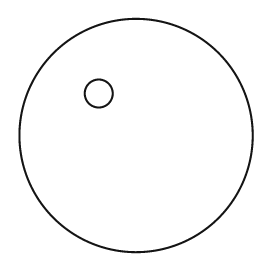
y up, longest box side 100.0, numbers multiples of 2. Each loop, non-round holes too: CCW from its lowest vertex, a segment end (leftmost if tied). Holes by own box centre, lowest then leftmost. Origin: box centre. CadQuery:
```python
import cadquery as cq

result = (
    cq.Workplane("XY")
    .moveTo(0.0, 0.0)
    .circle(50.0)
    .moveTo(-16.0, 18.0)
    .circle(6.0)
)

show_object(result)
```